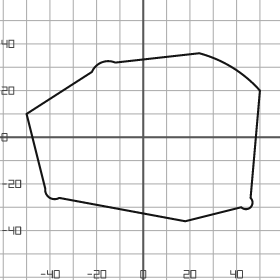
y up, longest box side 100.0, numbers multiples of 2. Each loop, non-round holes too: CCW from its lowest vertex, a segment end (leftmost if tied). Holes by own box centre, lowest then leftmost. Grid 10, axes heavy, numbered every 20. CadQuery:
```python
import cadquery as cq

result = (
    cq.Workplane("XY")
    .moveTo(18.0, -36.0)
    .lineTo(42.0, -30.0)
    .threePointArc((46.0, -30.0), (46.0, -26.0))
    .lineTo(50.0, 20.0)
    .threePointArc((38.0, 30.0), (24.0, 36.0))
    .lineTo(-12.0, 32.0)
    .threePointArc((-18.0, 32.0), (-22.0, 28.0))
    .lineTo(-50.0, 10.0)
    .lineTo(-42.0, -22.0)
    .threePointArc((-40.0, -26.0), (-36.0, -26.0))
    .close()
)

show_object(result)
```